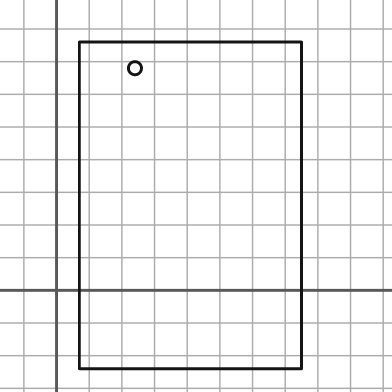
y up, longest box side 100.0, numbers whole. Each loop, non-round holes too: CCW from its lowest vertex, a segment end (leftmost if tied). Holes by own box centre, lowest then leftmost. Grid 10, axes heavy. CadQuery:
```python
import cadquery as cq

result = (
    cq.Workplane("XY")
    .moveTo(7.0, -24.0)
    .lineTo(75.0, -24.0)
    .lineTo(75.0, 76.0)
    .lineTo(7.0, 76.0)
    .close()
    .moveTo(24.0, 68.0)
    .circle(2.0)
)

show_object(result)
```